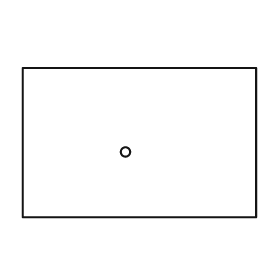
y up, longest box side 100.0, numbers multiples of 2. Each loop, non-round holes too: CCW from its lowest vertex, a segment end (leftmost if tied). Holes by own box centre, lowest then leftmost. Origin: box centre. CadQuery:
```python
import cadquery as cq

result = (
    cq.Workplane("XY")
    .moveTo(-50.0, -32.0)
    .lineTo(50.0, -32.0)
    .lineTo(50.0, 32.0)
    .lineTo(-50.0, 32.0)
    .close()
    .moveTo(-6.0, -4.0)
    .circle(2.0)
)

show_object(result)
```